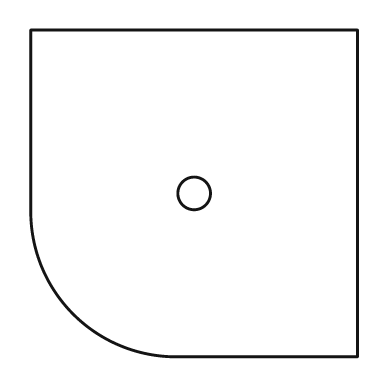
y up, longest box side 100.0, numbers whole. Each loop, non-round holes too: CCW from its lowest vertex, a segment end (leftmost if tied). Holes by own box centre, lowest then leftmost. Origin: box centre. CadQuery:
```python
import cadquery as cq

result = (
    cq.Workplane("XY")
    .moveTo(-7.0, -50.0)
    .lineTo(50.0, -50.0)
    .lineTo(50.0, 50.0)
    .lineTo(-50.0, 50.0)
    .lineTo(-50.0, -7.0)
    .threePointArc((-37.0, -37.0), (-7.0, -50.0))
    .close()
    .moveTo(0.0, 0.0)
    .circle(5.0)
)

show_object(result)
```